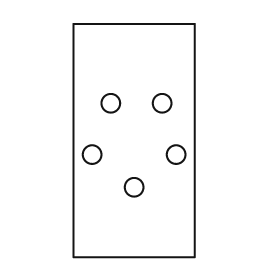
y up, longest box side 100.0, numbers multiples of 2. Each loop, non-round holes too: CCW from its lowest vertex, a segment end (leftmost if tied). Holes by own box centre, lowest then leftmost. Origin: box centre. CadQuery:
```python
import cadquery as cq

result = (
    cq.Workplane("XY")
    .moveTo(-26.0, -50.0)
    .lineTo(26.0, -50.0)
    .lineTo(26.0, 50.0)
    .lineTo(-26.0, 50.0)
    .close()
    .moveTo(0.0, -20.0)
    .circle(4.0)
    .moveTo(-18.0, -6.0)
    .circle(4.0)
    .moveTo(18.0, -6.0)
    .circle(4.0)
    .moveTo(-10.0, 16.0)
    .circle(4.0)
    .moveTo(12.0, 16.0)
    .circle(4.0)
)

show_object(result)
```